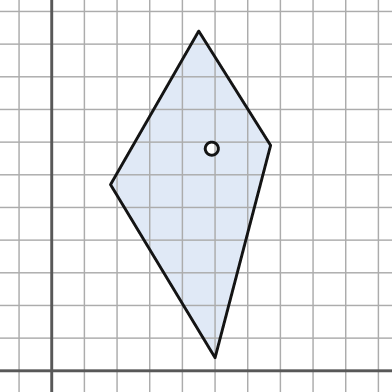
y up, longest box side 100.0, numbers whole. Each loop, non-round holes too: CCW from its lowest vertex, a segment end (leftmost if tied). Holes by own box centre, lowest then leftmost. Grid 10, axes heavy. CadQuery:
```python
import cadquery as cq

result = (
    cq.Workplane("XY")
    .moveTo(50.0, 4.0)
    .lineTo(67.0, 69.0)
    .lineTo(45.0, 104.0)
    .lineTo(18.0, 57.0)
    .close()
    .moveTo(49.0, 68.0)
    .circle(2.0)
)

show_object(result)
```